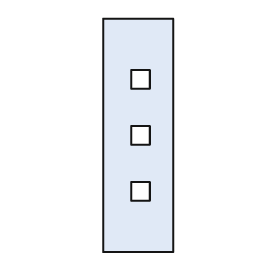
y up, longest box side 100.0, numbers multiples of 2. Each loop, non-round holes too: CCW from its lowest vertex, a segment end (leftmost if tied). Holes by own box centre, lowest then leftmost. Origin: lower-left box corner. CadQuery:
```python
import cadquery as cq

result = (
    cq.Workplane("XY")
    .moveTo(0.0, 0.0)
    .lineTo(30.0, 0.0)
    .lineTo(30.0, 100.0)
    .lineTo(0.0, 100.0)
    .close()
    .moveTo(12.0, 22.0)
    .lineTo(20.0, 22.0)
    .lineTo(20.0, 30.0)
    .lineTo(12.0, 30.0)
    .close()
    .moveTo(12.0, 46.0)
    .lineTo(20.0, 46.0)
    .lineTo(20.0, 54.0)
    .lineTo(12.0, 54.0)
    .close()
    .moveTo(12.0, 70.0)
    .lineTo(20.0, 70.0)
    .lineTo(20.0, 78.0)
    .lineTo(12.0, 78.0)
    .close()
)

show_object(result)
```